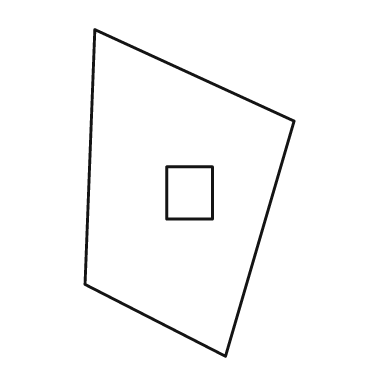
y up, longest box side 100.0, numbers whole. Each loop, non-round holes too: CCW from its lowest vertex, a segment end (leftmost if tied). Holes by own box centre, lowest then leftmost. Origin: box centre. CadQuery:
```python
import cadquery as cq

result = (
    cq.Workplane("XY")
    .moveTo(11.0, -50.0)
    .lineTo(32.0, 22.0)
    .lineTo(-29.0, 50.0)
    .lineTo(-32.0, -28.0)
    .close()
    .moveTo(-7.0, -8.0)
    .lineTo(7.0, -8.0)
    .lineTo(7.0, 8.0)
    .lineTo(-7.0, 8.0)
    .close()
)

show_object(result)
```